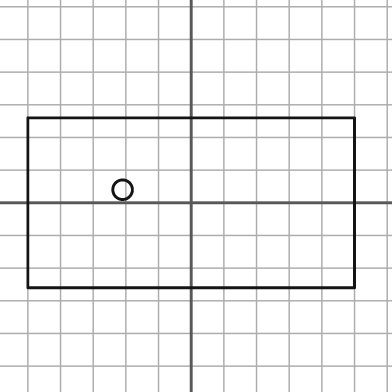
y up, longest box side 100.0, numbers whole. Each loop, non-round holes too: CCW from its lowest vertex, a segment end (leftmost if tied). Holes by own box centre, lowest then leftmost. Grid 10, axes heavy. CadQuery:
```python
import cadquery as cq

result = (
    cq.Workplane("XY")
    .moveTo(-50.0, -26.0)
    .lineTo(50.0, -26.0)
    .lineTo(50.0, 26.0)
    .lineTo(-50.0, 26.0)
    .close()
    .moveTo(-21.0, 4.0)
    .circle(3.0)
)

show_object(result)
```